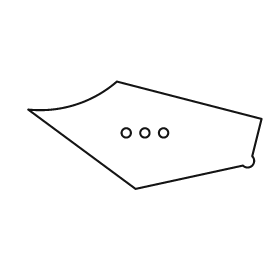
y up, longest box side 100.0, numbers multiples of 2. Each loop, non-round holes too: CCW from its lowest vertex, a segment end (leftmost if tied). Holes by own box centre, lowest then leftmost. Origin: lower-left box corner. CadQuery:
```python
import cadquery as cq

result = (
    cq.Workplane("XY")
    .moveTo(46.0, 0.0)
    .lineTo(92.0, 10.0)
    .threePointArc((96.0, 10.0), (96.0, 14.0))
    .lineTo(100.0, 30.0)
    .lineTo(38.0, 46.0)
    .threePointArc((20.0, 36.0), (0.0, 34.0))
    .close()
    .moveTo(42.0, 24.0)
    .circle(2.0)
    .moveTo(50.0, 24.0)
    .circle(2.0)
    .moveTo(58.0, 24.0)
    .circle(2.0)
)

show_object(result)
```